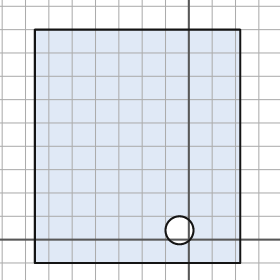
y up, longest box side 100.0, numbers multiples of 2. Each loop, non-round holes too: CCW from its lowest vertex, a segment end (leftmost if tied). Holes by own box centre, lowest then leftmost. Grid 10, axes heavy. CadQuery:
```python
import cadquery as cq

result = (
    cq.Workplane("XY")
    .moveTo(-66.0, -10.0)
    .lineTo(22.0, -10.0)
    .lineTo(22.0, 90.0)
    .lineTo(-66.0, 90.0)
    .close()
    .moveTo(-4.0, 4.0)
    .circle(6.0)
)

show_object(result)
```